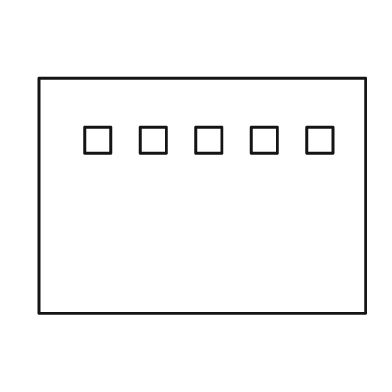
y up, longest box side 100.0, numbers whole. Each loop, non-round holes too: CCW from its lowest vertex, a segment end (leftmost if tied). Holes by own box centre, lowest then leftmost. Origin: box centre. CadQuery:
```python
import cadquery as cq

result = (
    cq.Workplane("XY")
    .moveTo(-50.0, -36.0)
    .lineTo(50.0, -36.0)
    .lineTo(50.0, 36.0)
    .lineTo(-50.0, 36.0)
    .close()
    .moveTo(-36.0, 13.0)
    .lineTo(-28.0, 13.0)
    .lineTo(-28.0, 21.0)
    .lineTo(-36.0, 21.0)
    .close()
    .moveTo(-19.0, 13.0)
    .lineTo(-11.0, 13.0)
    .lineTo(-11.0, 21.0)
    .lineTo(-19.0, 21.0)
    .close()
    .moveTo(-2.0, 13.0)
    .lineTo(6.0, 13.0)
    .lineTo(6.0, 21.0)
    .lineTo(-2.0, 21.0)
    .close()
    .moveTo(15.0, 13.0)
    .lineTo(23.0, 13.0)
    .lineTo(23.0, 21.0)
    .lineTo(15.0, 21.0)
    .close()
    .moveTo(32.0, 13.0)
    .lineTo(40.0, 13.0)
    .lineTo(40.0, 21.0)
    .lineTo(32.0, 21.0)
    .close()
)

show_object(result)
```